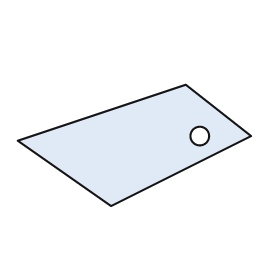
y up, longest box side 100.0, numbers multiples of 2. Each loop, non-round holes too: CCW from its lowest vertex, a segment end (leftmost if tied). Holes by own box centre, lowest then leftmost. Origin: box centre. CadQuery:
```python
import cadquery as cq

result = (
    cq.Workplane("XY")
    .moveTo(-10.0, -26.0)
    .lineTo(50.0, 4.0)
    .lineTo(22.0, 26.0)
    .lineTo(-50.0, 2.0)
    .close()
    .moveTo(28.0, 4.0)
    .circle(4.0)
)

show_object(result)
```